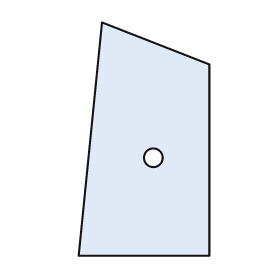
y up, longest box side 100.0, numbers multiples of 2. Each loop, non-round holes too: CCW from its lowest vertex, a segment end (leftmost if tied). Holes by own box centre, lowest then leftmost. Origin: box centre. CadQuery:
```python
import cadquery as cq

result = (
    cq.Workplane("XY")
    .moveTo(-28.0, -50.0)
    .lineTo(28.0, -50.0)
    .lineTo(28.0, 32.0)
    .lineTo(-18.0, 50.0)
    .close()
    .moveTo(4.0, -8.0)
    .circle(4.0)
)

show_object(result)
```